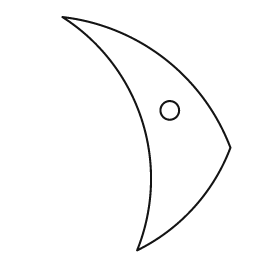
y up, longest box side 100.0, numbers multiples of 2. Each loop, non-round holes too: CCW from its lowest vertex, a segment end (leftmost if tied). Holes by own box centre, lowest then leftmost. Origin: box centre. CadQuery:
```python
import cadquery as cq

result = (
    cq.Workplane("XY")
    .moveTo(-4.0, -50.0)
    .threePointArc((20.0, -32.0), (36.0, -6.0))
    .threePointArc((8.0, 32.0), (-36.0, 50.0))
    .threePointArc((-2.0, 6.0), (-4.0, -50.0))
    .close()
    .moveTo(10.0, 10.0)
    .circle(4.0)
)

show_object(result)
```